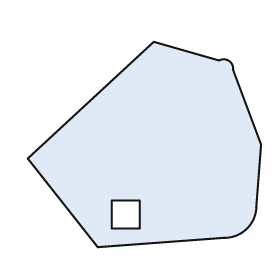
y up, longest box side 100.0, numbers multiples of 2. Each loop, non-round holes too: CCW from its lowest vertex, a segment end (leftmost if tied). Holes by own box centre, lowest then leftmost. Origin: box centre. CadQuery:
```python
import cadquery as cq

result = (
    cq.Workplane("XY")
    .moveTo(-20.0, -44.0)
    .lineTo(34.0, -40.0)
    .threePointArc((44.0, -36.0), (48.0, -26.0))
    .lineTo(50.0, 0.0)
    .lineTo(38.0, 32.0)
    .threePointArc((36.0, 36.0), (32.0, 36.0))
    .lineTo(4.0, 44.0)
    .lineTo(-50.0, -6.0)
    .close()
    .moveTo(-14.0, -36.0)
    .lineTo(-2.0, -36.0)
    .lineTo(-2.0, -24.0)
    .lineTo(-14.0, -24.0)
    .close()
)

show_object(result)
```